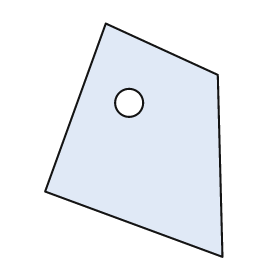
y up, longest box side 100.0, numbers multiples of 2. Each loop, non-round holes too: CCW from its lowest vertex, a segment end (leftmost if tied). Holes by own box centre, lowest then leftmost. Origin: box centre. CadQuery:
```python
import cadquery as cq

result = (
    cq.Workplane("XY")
    .moveTo(38.0, -50.0)
    .lineTo(36.0, 28.0)
    .lineTo(-12.0, 50.0)
    .lineTo(-38.0, -22.0)
    .close()
    .moveTo(-2.0, 16.0)
    .circle(6.0)
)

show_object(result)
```